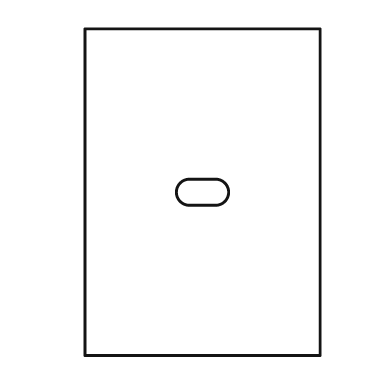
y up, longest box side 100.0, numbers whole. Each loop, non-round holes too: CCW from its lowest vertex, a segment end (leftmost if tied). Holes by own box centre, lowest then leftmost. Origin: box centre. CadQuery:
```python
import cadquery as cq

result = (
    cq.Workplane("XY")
    .moveTo(-36.0, -50.0)
    .lineTo(36.0, -50.0)
    .lineTo(36.0, 50.0)
    .lineTo(-36.0, 50.0)
    .close()
    .moveTo(-4.0, -4.0)
    .lineTo(4.0, -4.0)
    .threePointArc((8.0, 0.0), (4.0, 4.0))
    .lineTo(-4.0, 4.0)
    .threePointArc((-8.0, 0.0), (-4.0, -4.0))
    .close()
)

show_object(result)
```